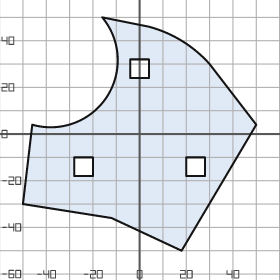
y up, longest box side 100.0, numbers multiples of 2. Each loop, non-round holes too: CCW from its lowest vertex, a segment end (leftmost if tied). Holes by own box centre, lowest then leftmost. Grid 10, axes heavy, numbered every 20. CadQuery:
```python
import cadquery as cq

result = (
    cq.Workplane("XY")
    .moveTo(18.0, -50.0)
    .lineTo(50.0, 4.0)
    .lineTo(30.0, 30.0)
    .threePointArc((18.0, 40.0), (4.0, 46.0))
    .lineTo(-16.0, 50.0)
    .threePointArc((-14.0, 16.0), (-46.0, 4.0))
    .lineTo(-50.0, -30.0)
    .lineTo(-12.0, -36.0)
    .close()
    .moveTo(-28.0, -18.0)
    .lineTo(-20.0, -18.0)
    .lineTo(-20.0, -10.0)
    .lineTo(-28.0, -10.0)
    .close()
    .moveTo(20.0, -18.0)
    .lineTo(28.0, -18.0)
    .lineTo(28.0, -10.0)
    .lineTo(20.0, -10.0)
    .close()
    .moveTo(-4.0, 24.0)
    .lineTo(4.0, 24.0)
    .lineTo(4.0, 32.0)
    .lineTo(-4.0, 32.0)
    .close()
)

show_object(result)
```